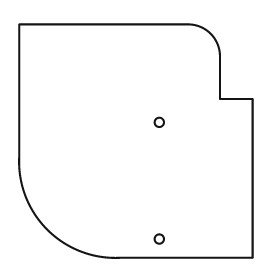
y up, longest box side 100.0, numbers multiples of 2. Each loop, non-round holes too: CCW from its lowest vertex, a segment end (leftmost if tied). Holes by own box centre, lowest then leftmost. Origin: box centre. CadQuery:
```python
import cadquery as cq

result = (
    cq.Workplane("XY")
    .moveTo(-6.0, -50.0)
    .lineTo(50.0, -50.0)
    .lineTo(50.0, 18.0)
    .lineTo(36.0, 18.0)
    .lineTo(36.0, 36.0)
    .threePointArc((32.0, 46.0), (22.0, 50.0))
    .lineTo(-50.0, 50.0)
    .lineTo(-50.0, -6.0)
    .threePointArc((-38.0, -38.0), (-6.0, -50.0))
    .close()
    .moveTo(10.0, -42.0)
    .circle(2.0)
    .moveTo(10.0, 8.0)
    .circle(2.0)
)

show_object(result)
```